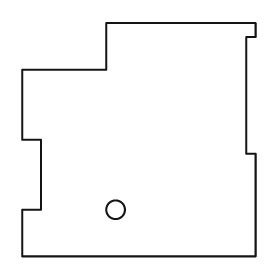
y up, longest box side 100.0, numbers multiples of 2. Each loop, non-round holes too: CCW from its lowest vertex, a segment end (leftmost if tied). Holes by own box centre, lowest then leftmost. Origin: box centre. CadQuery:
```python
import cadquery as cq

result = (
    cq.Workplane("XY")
    .moveTo(-50.0, -50.0)
    .lineTo(50.0, -50.0)
    .lineTo(50.0, -6.0)
    .lineTo(46.0, -6.0)
    .lineTo(46.0, 44.0)
    .lineTo(50.0, 44.0)
    .lineTo(50.0, 50.0)
    .lineTo(-14.0, 50.0)
    .lineTo(-14.0, 30.0)
    .lineTo(-50.0, 30.0)
    .lineTo(-50.0, 0.0)
    .lineTo(-42.0, 0.0)
    .lineTo(-42.0, -30.0)
    .lineTo(-50.0, -30.0)
    .close()
    .moveTo(-10.0, -30.0)
    .circle(4.0)
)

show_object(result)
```